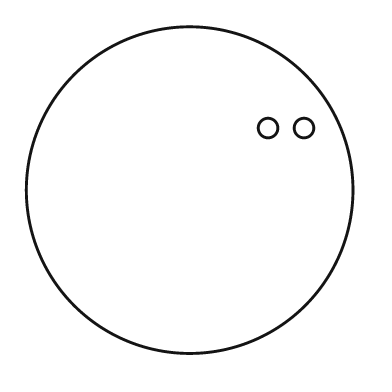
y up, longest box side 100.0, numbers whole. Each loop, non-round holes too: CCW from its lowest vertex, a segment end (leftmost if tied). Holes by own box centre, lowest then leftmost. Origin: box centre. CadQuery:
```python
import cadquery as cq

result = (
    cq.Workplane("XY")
    .moveTo(0.0, 0.0)
    .circle(50.0)
    .moveTo(24.0, 19.0)
    .circle(3.0)
    .moveTo(35.0, 19.0)
    .circle(3.0)
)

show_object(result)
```